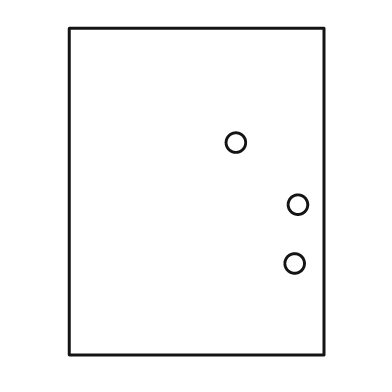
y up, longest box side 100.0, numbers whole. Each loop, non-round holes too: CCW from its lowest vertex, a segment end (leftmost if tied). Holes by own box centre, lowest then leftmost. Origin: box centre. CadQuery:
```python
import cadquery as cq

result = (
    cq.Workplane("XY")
    .moveTo(-39.0, -50.0)
    .lineTo(39.0, -50.0)
    .lineTo(39.0, 50.0)
    .lineTo(-39.0, 50.0)
    .close()
    .moveTo(30.0, -22.0)
    .circle(3.0)
    .moveTo(31.0, -4.0)
    .circle(3.0)
    .moveTo(12.0, 15.0)
    .circle(3.0)
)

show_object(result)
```